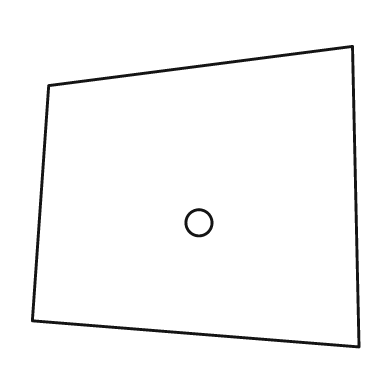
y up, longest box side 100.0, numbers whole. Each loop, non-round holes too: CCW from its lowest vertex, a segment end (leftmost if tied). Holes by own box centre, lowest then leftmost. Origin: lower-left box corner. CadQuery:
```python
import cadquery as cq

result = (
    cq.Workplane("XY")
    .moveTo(100.0, 0.0)
    .lineTo(98.0, 92.0)
    .lineTo(5.0, 80.0)
    .lineTo(0.0, 8.0)
    .close()
    .moveTo(51.0, 38.0)
    .circle(4.0)
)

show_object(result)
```